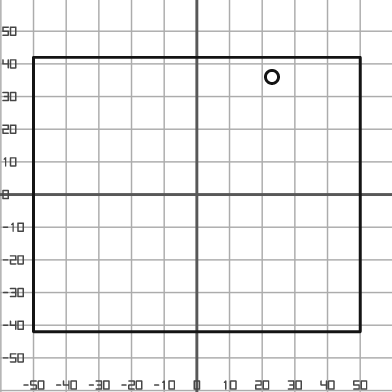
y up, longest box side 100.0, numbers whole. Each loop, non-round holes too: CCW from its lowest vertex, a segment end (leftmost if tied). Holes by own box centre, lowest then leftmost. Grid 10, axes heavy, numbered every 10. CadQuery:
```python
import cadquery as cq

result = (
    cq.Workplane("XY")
    .moveTo(-50.0, -42.0)
    .lineTo(50.0, -42.0)
    .lineTo(50.0, 42.0)
    .lineTo(-50.0, 42.0)
    .close()
    .moveTo(23.0, 36.0)
    .circle(2.0)
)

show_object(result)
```